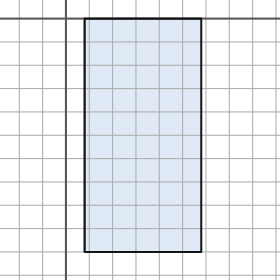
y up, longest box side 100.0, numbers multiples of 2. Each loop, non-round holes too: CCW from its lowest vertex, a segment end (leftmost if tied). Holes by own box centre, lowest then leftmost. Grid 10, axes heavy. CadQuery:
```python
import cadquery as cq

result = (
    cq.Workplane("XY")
    .moveTo(8.0, -100.0)
    .lineTo(58.0, -100.0)
    .lineTo(58.0, 0.0)
    .lineTo(8.0, 0.0)
    .close()
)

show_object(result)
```